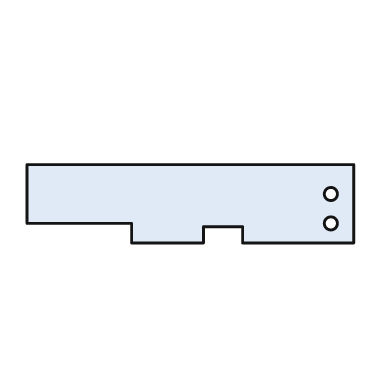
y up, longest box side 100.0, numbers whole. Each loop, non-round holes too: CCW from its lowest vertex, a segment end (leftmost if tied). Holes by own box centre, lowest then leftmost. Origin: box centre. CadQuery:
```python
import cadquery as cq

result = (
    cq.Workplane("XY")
    .moveTo(-18.0, -12.0)
    .lineTo(4.0, -12.0)
    .lineTo(4.0, -7.0)
    .lineTo(16.0, -7.0)
    .lineTo(16.0, -12.0)
    .lineTo(50.0, -12.0)
    .lineTo(50.0, 12.0)
    .lineTo(-50.0, 12.0)
    .lineTo(-50.0, -6.0)
    .lineTo(-18.0, -6.0)
    .close()
    .moveTo(43.0, -6.0)
    .circle(2.0)
    .moveTo(43.0, 3.0)
    .circle(2.0)
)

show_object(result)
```